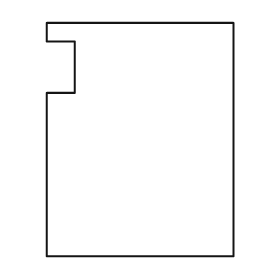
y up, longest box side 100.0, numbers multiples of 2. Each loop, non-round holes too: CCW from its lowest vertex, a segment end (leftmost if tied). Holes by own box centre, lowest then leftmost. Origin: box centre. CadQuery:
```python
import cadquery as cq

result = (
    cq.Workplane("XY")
    .moveTo(-40.0, -50.0)
    .lineTo(40.0, -50.0)
    .lineTo(40.0, 50.0)
    .lineTo(-40.0, 50.0)
    .lineTo(-40.0, 42.0)
    .lineTo(-28.0, 42.0)
    .lineTo(-28.0, 20.0)
    .lineTo(-40.0, 20.0)
    .close()
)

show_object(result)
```